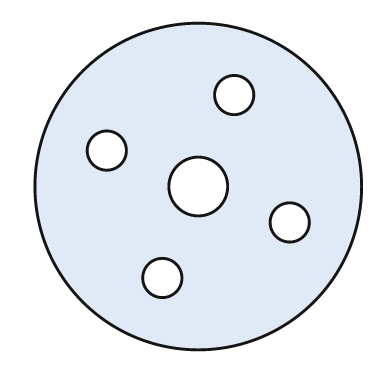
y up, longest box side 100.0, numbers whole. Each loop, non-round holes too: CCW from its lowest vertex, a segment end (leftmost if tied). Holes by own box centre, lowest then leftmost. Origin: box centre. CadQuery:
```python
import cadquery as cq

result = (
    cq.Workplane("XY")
    .moveTo(0.0, 0.0)
    .circle(50.0)
    .moveTo(-11.0, -28.0)
    .circle(6.0)
    .moveTo(28.0, -11.0)
    .circle(6.0)
    .moveTo(0.0, 0.0)
    .circle(9.0)
    .moveTo(-28.0, 11.0)
    .circle(6.0)
    .moveTo(11.0, 28.0)
    .circle(6.0)
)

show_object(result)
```